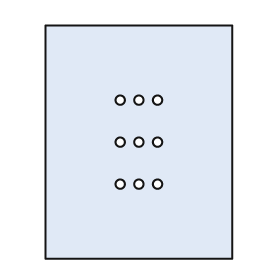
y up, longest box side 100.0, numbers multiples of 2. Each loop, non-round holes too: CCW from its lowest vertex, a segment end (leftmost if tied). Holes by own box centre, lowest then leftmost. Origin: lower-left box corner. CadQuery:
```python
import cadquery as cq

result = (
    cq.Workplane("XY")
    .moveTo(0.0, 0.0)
    .lineTo(80.0, 0.0)
    .lineTo(80.0, 100.0)
    .lineTo(0.0, 100.0)
    .close()
    .moveTo(32.0, 32.0)
    .circle(2.0)
    .moveTo(40.0, 32.0)
    .circle(2.0)
    .moveTo(48.0, 32.0)
    .circle(2.0)
    .moveTo(32.0, 50.0)
    .circle(2.0)
    .moveTo(40.0, 50.0)
    .circle(2.0)
    .moveTo(48.0, 50.0)
    .circle(2.0)
    .moveTo(32.0, 68.0)
    .circle(2.0)
    .moveTo(40.0, 68.0)
    .circle(2.0)
    .moveTo(48.0, 68.0)
    .circle(2.0)
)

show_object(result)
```